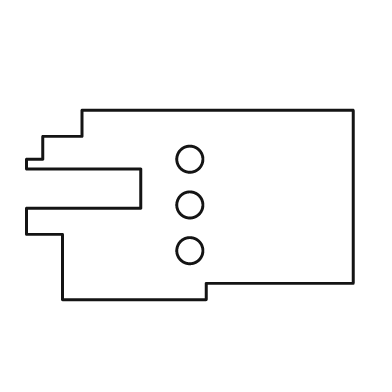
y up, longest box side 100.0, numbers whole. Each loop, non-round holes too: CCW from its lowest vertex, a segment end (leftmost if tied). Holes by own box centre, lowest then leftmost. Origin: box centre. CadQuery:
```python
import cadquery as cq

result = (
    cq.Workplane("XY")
    .moveTo(-39.0, -29.0)
    .lineTo(5.0, -29.0)
    .lineTo(5.0, -24.0)
    .lineTo(50.0, -24.0)
    .lineTo(50.0, 29.0)
    .lineTo(-33.0, 29.0)
    .lineTo(-33.0, 21.0)
    .lineTo(-45.0, 21.0)
    .lineTo(-45.0, 14.0)
    .lineTo(-50.0, 14.0)
    .lineTo(-50.0, 11.0)
    .lineTo(-15.0, 11.0)
    .lineTo(-15.0, -1.0)
    .lineTo(-50.0, -1.0)
    .lineTo(-50.0, -9.0)
    .lineTo(-39.0, -9.0)
    .close()
    .moveTo(0.0, -14.0)
    .circle(4.0)
    .moveTo(0.0, 0.0)
    .circle(4.0)
    .moveTo(0.0, 14.0)
    .circle(4.0)
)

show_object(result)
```